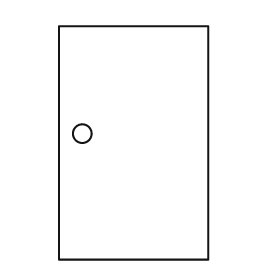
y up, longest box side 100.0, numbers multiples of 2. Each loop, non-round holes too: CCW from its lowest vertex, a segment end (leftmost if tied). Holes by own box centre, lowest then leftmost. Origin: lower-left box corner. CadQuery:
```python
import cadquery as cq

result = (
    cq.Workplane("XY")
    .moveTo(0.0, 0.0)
    .lineTo(64.0, 0.0)
    .lineTo(64.0, 100.0)
    .lineTo(0.0, 100.0)
    .close()
    .moveTo(10.0, 54.0)
    .circle(4.0)
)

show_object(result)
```